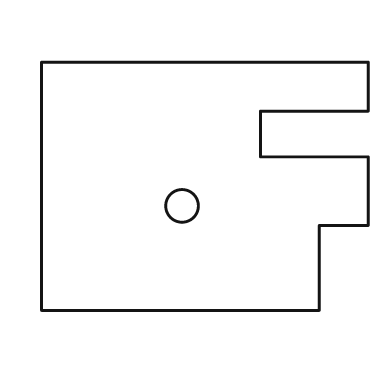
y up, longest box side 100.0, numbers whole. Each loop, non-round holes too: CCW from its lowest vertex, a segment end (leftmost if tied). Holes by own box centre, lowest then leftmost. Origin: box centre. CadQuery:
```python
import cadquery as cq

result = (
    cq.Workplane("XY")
    .moveTo(-50.0, -38.0)
    .lineTo(35.0, -38.0)
    .lineTo(35.0, -12.0)
    .lineTo(50.0, -12.0)
    .lineTo(50.0, 9.0)
    .lineTo(17.0, 9.0)
    .lineTo(17.0, 23.0)
    .lineTo(50.0, 23.0)
    .lineTo(50.0, 38.0)
    .lineTo(-50.0, 38.0)
    .close()
    .moveTo(-7.0, -6.0)
    .circle(5.0)
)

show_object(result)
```